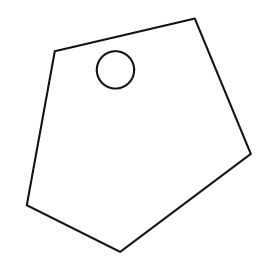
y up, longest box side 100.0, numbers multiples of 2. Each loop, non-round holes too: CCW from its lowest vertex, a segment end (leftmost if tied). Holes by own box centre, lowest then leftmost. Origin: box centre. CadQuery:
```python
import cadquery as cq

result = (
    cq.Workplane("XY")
    .moveTo(-8.0, -50.0)
    .lineTo(48.0, -8.0)
    .lineTo(24.0, 50.0)
    .lineTo(-36.0, 36.0)
    .lineTo(-48.0, -30.0)
    .close()
    .moveTo(-10.0, 28.0)
    .circle(8.0)
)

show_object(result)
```